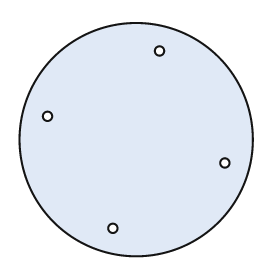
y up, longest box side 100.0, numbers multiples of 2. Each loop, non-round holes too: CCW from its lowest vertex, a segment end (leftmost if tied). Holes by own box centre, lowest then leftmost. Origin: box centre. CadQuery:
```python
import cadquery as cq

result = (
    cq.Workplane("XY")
    .moveTo(0.0, 0.0)
    .circle(50.0)
    .moveTo(-10.0, -38.0)
    .circle(2.0)
    .moveTo(38.0, -10.0)
    .circle(2.0)
    .moveTo(-38.0, 10.0)
    .circle(2.0)
    .moveTo(10.0, 38.0)
    .circle(2.0)
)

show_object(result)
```